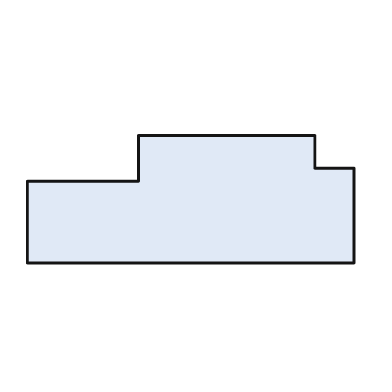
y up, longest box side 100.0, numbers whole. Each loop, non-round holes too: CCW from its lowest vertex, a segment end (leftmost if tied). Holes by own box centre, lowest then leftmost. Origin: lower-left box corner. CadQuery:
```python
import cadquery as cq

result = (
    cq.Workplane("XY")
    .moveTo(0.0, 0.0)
    .lineTo(100.0, 0.0)
    .lineTo(100.0, 29.0)
    .lineTo(88.0, 29.0)
    .lineTo(88.0, 39.0)
    .lineTo(34.0, 39.0)
    .lineTo(34.0, 25.0)
    .lineTo(0.0, 25.0)
    .close()
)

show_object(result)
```